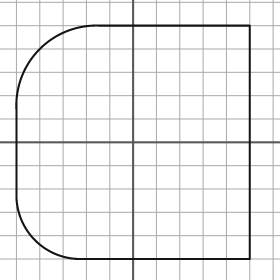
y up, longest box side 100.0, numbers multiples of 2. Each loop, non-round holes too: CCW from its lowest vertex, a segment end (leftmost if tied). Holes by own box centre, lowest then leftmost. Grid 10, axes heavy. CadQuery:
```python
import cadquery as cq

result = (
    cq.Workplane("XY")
    .moveTo(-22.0, -50.0)
    .lineTo(50.0, -50.0)
    .lineTo(50.0, 50.0)
    .lineTo(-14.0, 50.0)
    .threePointArc((-40.0, 40.0), (-50.0, 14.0))
    .lineTo(-50.0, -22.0)
    .threePointArc((-42.0, -42.0), (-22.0, -50.0))
    .close()
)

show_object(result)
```